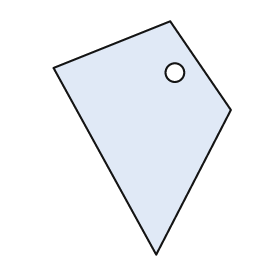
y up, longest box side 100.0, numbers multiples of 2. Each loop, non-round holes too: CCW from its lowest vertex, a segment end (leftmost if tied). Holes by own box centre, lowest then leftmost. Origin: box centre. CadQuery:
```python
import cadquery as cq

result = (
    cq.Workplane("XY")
    .moveTo(6.0, -50.0)
    .lineTo(38.0, 12.0)
    .lineTo(12.0, 50.0)
    .lineTo(-38.0, 30.0)
    .close()
    .moveTo(14.0, 28.0)
    .circle(4.0)
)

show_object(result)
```